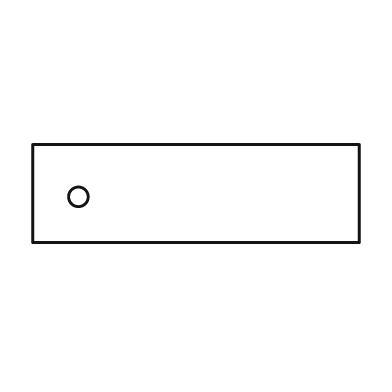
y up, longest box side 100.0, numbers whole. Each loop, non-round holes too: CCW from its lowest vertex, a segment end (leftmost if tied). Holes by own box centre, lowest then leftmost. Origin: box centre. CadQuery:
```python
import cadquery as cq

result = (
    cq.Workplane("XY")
    .moveTo(-50.0, -15.0)
    .lineTo(50.0, -15.0)
    .lineTo(50.0, 15.0)
    .lineTo(-50.0, 15.0)
    .close()
    .moveTo(-36.0, -1.0)
    .circle(3.0)
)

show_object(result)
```